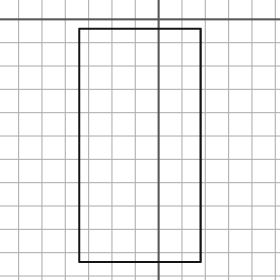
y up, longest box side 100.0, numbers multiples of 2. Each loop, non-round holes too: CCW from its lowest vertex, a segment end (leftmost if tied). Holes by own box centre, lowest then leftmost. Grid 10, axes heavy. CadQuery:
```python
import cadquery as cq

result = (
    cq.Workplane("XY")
    .moveTo(-34.0, -104.0)
    .lineTo(18.0, -104.0)
    .lineTo(18.0, -4.0)
    .lineTo(-34.0, -4.0)
    .close()
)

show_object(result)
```